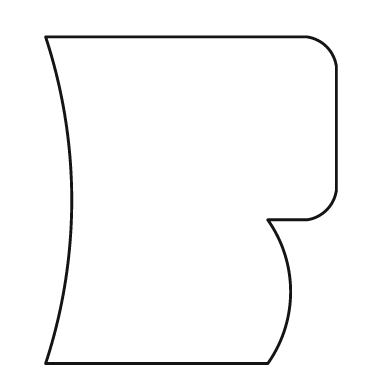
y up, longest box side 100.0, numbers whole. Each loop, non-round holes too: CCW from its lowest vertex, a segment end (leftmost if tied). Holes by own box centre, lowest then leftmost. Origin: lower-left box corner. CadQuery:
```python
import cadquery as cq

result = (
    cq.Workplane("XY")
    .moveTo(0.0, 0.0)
    .lineTo(68.0, 0.0)
    .threePointArc((75.0, 22.0), (68.0, 44.0))
    .lineTo(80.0, 44.0)
    .threePointArc((86.0, 47.0), (89.0, 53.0))
    .lineTo(89.0, 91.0)
    .threePointArc((86.0, 97.0), (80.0, 100.0))
    .lineTo(0.0, 100.0)
    .threePointArc((8.0, 50.0), (0.0, 0.0))
    .close()
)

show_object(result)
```